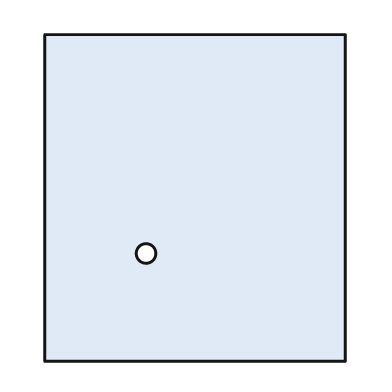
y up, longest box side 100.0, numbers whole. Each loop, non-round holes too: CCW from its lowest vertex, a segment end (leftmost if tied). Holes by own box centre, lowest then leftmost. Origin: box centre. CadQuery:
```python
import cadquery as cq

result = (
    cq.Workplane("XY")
    .moveTo(-46.0, -50.0)
    .lineTo(46.0, -50.0)
    .lineTo(46.0, 50.0)
    .lineTo(-46.0, 50.0)
    .close()
    .moveTo(-15.0, -17.0)
    .circle(3.0)
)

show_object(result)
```